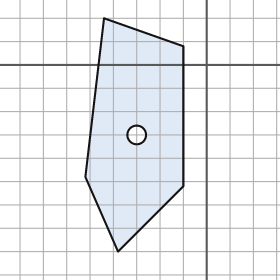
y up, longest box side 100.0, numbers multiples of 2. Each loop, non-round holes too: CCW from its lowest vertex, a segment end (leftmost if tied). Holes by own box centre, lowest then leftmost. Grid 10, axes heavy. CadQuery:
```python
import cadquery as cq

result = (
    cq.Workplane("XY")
    .moveTo(-38.0, -80.0)
    .lineTo(-10.0, -52.0)
    .lineTo(-10.0, 8.0)
    .lineTo(-44.0, 20.0)
    .lineTo(-52.0, -48.0)
    .close()
    .moveTo(-30.0, -30.0)
    .circle(4.0)
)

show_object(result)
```